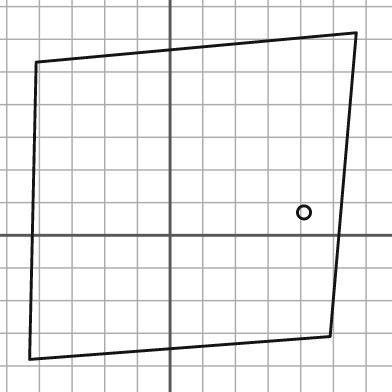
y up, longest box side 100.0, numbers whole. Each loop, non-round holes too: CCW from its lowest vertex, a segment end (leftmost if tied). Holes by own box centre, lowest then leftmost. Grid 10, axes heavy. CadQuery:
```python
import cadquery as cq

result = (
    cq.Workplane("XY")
    .moveTo(-43.0, -38.0)
    .lineTo(49.0, -31.0)
    .lineTo(57.0, 62.0)
    .lineTo(-41.0, 53.0)
    .close()
    .moveTo(41.0, 7.0)
    .circle(2.0)
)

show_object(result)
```